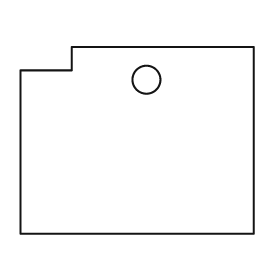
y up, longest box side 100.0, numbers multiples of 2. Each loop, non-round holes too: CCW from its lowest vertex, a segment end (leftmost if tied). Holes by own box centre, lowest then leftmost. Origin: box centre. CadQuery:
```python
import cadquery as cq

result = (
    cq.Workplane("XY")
    .moveTo(-50.0, -40.0)
    .lineTo(50.0, -40.0)
    .lineTo(50.0, 40.0)
    .lineTo(-28.0, 40.0)
    .lineTo(-28.0, 30.0)
    .lineTo(-50.0, 30.0)
    .close()
    .moveTo(4.0, 26.0)
    .circle(6.0)
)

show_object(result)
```